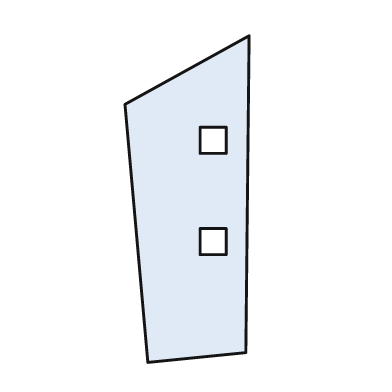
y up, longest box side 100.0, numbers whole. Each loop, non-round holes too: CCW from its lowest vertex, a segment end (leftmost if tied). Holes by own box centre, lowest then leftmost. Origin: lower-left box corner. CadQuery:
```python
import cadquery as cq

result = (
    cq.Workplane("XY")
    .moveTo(7.0, 0.0)
    .lineTo(37.0, 3.0)
    .lineTo(38.0, 100.0)
    .lineTo(0.0, 79.0)
    .close()
    .moveTo(23.0, 33.0)
    .lineTo(31.0, 33.0)
    .lineTo(31.0, 41.0)
    .lineTo(23.0, 41.0)
    .close()
    .moveTo(23.0, 64.0)
    .lineTo(31.0, 64.0)
    .lineTo(31.0, 72.0)
    .lineTo(23.0, 72.0)
    .close()
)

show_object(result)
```